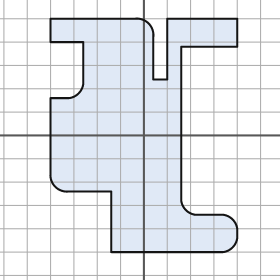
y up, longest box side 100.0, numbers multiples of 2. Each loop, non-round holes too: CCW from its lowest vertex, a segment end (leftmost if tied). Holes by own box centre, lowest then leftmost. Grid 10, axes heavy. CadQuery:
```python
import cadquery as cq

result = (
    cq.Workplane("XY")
    .moveTo(-14.0, -50.0)
    .lineTo(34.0, -50.0)
    .threePointArc((38.0, -48.0), (40.0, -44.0))
    .lineTo(40.0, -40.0)
    .threePointArc((38.0, -36.0), (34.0, -34.0))
    .lineTo(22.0, -34.0)
    .threePointArc((18.0, -32.0), (16.0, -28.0))
    .lineTo(16.0, 38.0)
    .lineTo(40.0, 38.0)
    .lineTo(40.0, 50.0)
    .lineTo(10.0, 50.0)
    .lineTo(10.0, 24.0)
    .lineTo(4.0, 24.0)
    .lineTo(4.0, 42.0)
    .threePointArc((2.0, 48.0), (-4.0, 50.0))
    .lineTo(-40.0, 50.0)
    .lineTo(-40.0, 40.0)
    .lineTo(-26.0, 40.0)
    .lineTo(-26.0, 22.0)
    .threePointArc((-28.0, 18.0), (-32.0, 16.0))
    .lineTo(-40.0, 16.0)
    .lineTo(-40.0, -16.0)
    .threePointArc((-38.0, -22.0), (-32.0, -24.0))
    .lineTo(-14.0, -24.0)
    .close()
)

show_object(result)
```